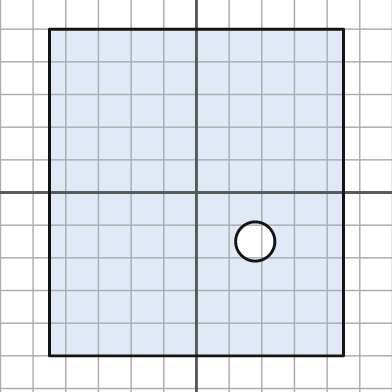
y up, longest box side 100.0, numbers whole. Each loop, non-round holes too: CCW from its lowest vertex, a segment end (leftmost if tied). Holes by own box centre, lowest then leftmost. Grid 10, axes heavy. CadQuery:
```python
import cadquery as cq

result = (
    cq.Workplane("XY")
    .moveTo(-45.0, -50.0)
    .lineTo(45.0, -50.0)
    .lineTo(45.0, 50.0)
    .lineTo(-45.0, 50.0)
    .close()
    .moveTo(18.0, -15.0)
    .circle(6.0)
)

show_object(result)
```